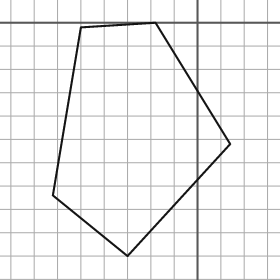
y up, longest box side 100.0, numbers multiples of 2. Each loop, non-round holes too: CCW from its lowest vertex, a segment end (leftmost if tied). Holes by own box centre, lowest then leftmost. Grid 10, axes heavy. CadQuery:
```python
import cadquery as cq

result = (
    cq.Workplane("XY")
    .moveTo(-30.0, -100.0)
    .lineTo(14.0, -52.0)
    .lineTo(-18.0, 0.0)
    .lineTo(-50.0, -2.0)
    .lineTo(-62.0, -74.0)
    .close()
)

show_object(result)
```